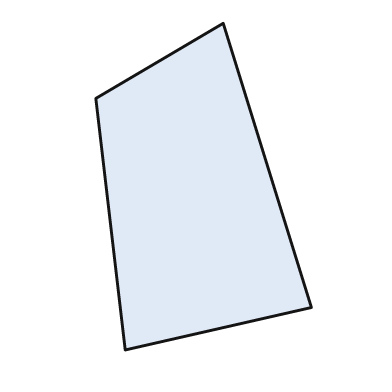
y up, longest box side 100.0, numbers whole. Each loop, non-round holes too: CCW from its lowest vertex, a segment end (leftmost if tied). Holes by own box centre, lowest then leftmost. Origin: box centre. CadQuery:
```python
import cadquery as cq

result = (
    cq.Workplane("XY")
    .moveTo(-24.0, -50.0)
    .lineTo(33.0, -37.0)
    .lineTo(6.0, 50.0)
    .lineTo(-33.0, 27.0)
    .close()
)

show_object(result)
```